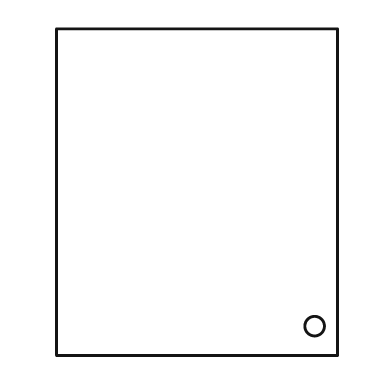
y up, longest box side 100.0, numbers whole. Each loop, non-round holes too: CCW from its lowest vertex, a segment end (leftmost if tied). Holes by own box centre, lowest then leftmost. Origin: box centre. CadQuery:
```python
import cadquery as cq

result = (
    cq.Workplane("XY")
    .moveTo(-43.0, -50.0)
    .lineTo(43.0, -50.0)
    .lineTo(43.0, 50.0)
    .lineTo(-43.0, 50.0)
    .close()
    .moveTo(36.0, -41.0)
    .circle(3.0)
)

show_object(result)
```